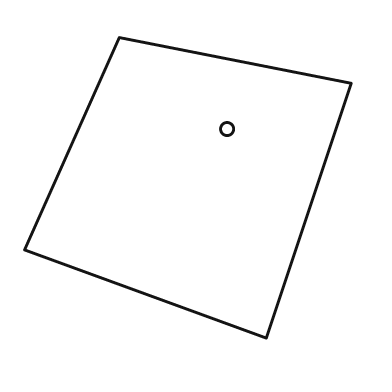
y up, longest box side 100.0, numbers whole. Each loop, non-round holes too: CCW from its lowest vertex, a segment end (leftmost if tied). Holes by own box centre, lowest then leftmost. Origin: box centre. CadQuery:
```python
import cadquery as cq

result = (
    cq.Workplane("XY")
    .moveTo(24.0, -46.0)
    .lineTo(50.0, 32.0)
    .lineTo(-21.0, 46.0)
    .lineTo(-50.0, -19.0)
    .close()
    .moveTo(12.0, 18.0)
    .circle(2.0)
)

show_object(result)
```